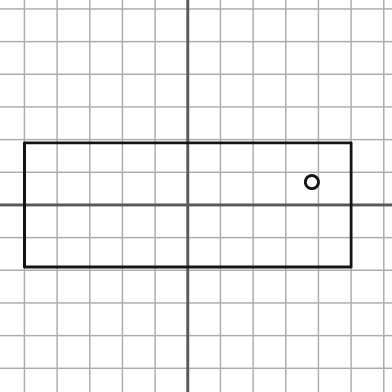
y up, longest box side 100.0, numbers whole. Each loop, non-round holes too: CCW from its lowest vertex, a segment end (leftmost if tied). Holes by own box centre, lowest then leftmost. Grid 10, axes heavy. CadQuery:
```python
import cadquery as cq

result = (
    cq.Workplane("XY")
    .moveTo(-50.0, -19.0)
    .lineTo(50.0, -19.0)
    .lineTo(50.0, 19.0)
    .lineTo(-50.0, 19.0)
    .close()
    .moveTo(38.0, 7.0)
    .circle(2.0)
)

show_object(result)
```